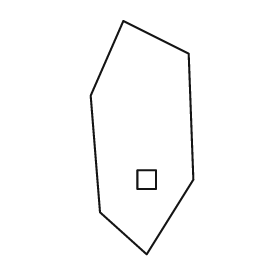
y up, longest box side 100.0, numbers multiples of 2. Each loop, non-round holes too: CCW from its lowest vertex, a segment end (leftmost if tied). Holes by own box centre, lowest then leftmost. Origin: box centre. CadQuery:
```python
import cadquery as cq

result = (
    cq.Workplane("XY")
    .moveTo(2.0, -50.0)
    .lineTo(22.0, -18.0)
    .lineTo(20.0, 36.0)
    .lineTo(-8.0, 50.0)
    .lineTo(-22.0, 18.0)
    .lineTo(-18.0, -32.0)
    .close()
    .moveTo(-2.0, -22.0)
    .lineTo(6.0, -22.0)
    .lineTo(6.0, -14.0)
    .lineTo(-2.0, -14.0)
    .close()
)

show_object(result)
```